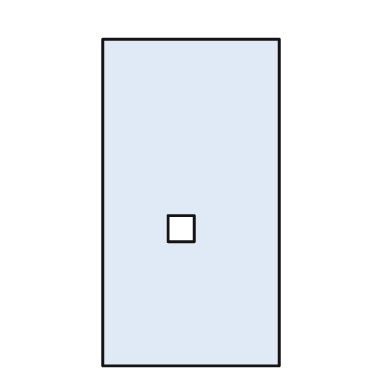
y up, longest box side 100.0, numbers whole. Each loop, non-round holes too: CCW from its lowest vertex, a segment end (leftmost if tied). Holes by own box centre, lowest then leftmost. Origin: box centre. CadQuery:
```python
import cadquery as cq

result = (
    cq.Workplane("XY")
    .moveTo(-27.0, -50.0)
    .lineTo(27.0, -50.0)
    .lineTo(27.0, 50.0)
    .lineTo(-27.0, 50.0)
    .close()
    .moveTo(-7.0, -12.0)
    .lineTo(1.0, -12.0)
    .lineTo(1.0, -4.0)
    .lineTo(-7.0, -4.0)
    .close()
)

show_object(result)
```